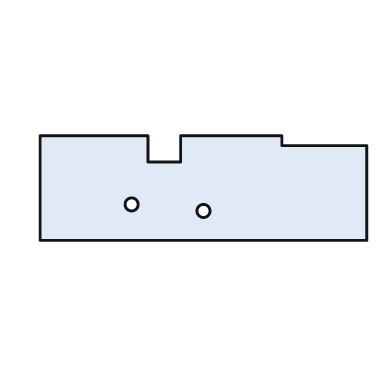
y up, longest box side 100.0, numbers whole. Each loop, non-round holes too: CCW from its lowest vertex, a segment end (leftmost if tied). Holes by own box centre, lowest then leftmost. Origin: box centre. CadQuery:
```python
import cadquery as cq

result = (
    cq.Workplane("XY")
    .moveTo(-50.0, -16.0)
    .lineTo(50.0, -16.0)
    .lineTo(50.0, 13.0)
    .lineTo(24.0, 13.0)
    .lineTo(24.0, 16.0)
    .lineTo(-7.0, 16.0)
    .lineTo(-7.0, 8.0)
    .lineTo(-17.0, 8.0)
    .lineTo(-17.0, 16.0)
    .lineTo(-50.0, 16.0)
    .close()
    .moveTo(0.0, -7.0)
    .circle(2.0)
    .moveTo(-22.0, -5.0)
    .circle(2.0)
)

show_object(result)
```